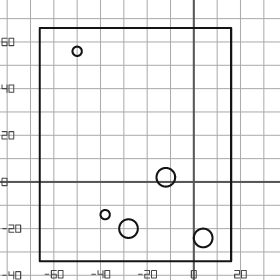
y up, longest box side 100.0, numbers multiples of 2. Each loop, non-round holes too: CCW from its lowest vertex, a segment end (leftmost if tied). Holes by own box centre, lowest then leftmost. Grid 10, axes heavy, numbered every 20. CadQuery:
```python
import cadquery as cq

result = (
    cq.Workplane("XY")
    .moveTo(-66.0, -34.0)
    .lineTo(16.0, -34.0)
    .lineTo(16.0, 66.0)
    .lineTo(-66.0, 66.0)
    .close()
    .moveTo(4.0, -24.0)
    .circle(4.0)
    .moveTo(-28.0, -20.0)
    .circle(4.0)
    .moveTo(-38.0, -14.0)
    .circle(2.0)
    .moveTo(-12.0, 2.0)
    .circle(4.0)
    .moveTo(-50.0, 56.0)
    .circle(2.0)
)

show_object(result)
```